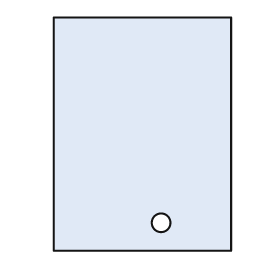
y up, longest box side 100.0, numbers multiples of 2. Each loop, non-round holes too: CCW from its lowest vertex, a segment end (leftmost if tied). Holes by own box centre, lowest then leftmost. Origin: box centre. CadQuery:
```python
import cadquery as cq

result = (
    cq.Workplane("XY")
    .moveTo(-38.0, -50.0)
    .lineTo(38.0, -50.0)
    .lineTo(38.0, 50.0)
    .lineTo(-38.0, 50.0)
    .close()
    .moveTo(8.0, -38.0)
    .circle(4.0)
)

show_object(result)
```